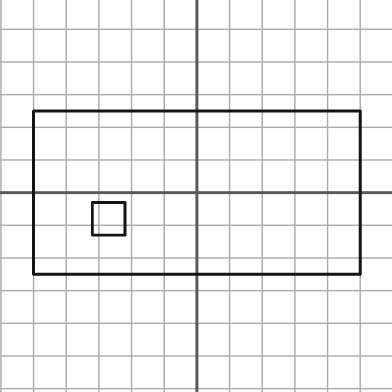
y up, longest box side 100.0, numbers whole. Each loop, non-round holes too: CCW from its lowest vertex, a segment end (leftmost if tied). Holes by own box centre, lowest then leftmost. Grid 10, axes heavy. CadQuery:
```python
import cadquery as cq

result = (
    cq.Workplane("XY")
    .moveTo(-50.0, -25.0)
    .lineTo(50.0, -25.0)
    .lineTo(50.0, 25.0)
    .lineTo(-50.0, 25.0)
    .close()
    .moveTo(-32.0, -13.0)
    .lineTo(-22.0, -13.0)
    .lineTo(-22.0, -3.0)
    .lineTo(-32.0, -3.0)
    .close()
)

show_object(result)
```